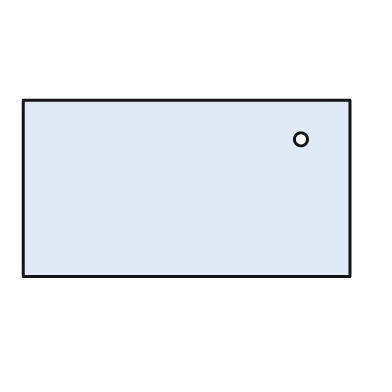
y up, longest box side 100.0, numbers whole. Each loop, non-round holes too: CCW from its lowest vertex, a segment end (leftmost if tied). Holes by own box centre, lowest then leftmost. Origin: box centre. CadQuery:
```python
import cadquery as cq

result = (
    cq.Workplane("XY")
    .moveTo(-50.0, -27.0)
    .lineTo(50.0, -27.0)
    .lineTo(50.0, 27.0)
    .lineTo(-50.0, 27.0)
    .close()
    .moveTo(35.0, 15.0)
    .circle(2.0)
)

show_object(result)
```